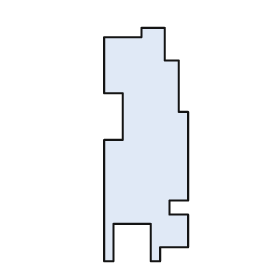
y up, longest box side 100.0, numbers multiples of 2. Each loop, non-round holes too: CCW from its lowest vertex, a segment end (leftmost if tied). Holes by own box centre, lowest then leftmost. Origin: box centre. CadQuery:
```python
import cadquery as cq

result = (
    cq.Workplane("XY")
    .moveTo(-18.0, -50.0)
    .lineTo(-14.0, -50.0)
    .lineTo(-14.0, -34.0)
    .lineTo(2.0, -34.0)
    .lineTo(2.0, -50.0)
    .lineTo(6.0, -50.0)
    .lineTo(6.0, -44.0)
    .lineTo(18.0, -44.0)
    .lineTo(18.0, -30.0)
    .lineTo(10.0, -30.0)
    .lineTo(10.0, -24.0)
    .lineTo(18.0, -24.0)
    .lineTo(18.0, 14.0)
    .lineTo(14.0, 14.0)
    .lineTo(14.0, 36.0)
    .lineTo(8.0, 36.0)
    .lineTo(8.0, 50.0)
    .lineTo(-2.0, 50.0)
    .lineTo(-2.0, 46.0)
    .lineTo(-18.0, 46.0)
    .lineTo(-18.0, 22.0)
    .lineTo(-10.0, 22.0)
    .lineTo(-10.0, 2.0)
    .lineTo(-18.0, 2.0)
    .close()
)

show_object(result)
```